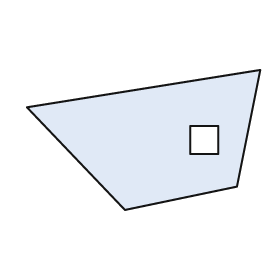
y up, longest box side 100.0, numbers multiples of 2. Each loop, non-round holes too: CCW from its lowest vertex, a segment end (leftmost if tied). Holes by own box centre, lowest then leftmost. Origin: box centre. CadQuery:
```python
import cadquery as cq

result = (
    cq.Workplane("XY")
    .moveTo(-8.0, -30.0)
    .lineTo(40.0, -20.0)
    .lineTo(50.0, 30.0)
    .lineTo(-50.0, 14.0)
    .close()
    .moveTo(20.0, -6.0)
    .lineTo(32.0, -6.0)
    .lineTo(32.0, 6.0)
    .lineTo(20.0, 6.0)
    .close()
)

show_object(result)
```